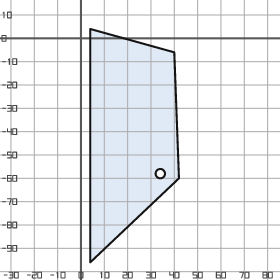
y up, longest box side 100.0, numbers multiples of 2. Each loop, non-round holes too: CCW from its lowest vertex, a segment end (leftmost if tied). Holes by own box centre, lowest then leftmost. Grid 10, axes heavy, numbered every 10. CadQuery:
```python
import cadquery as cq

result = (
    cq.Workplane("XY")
    .moveTo(4.0, -96.0)
    .lineTo(42.0, -60.0)
    .lineTo(40.0, -6.0)
    .lineTo(4.0, 4.0)
    .close()
    .moveTo(34.0, -58.0)
    .circle(2.0)
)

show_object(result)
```